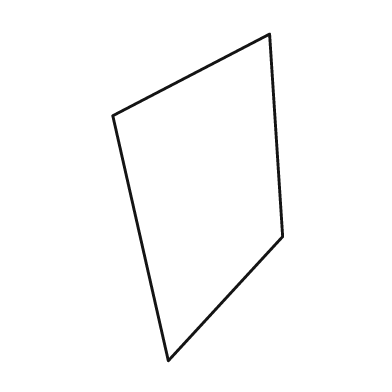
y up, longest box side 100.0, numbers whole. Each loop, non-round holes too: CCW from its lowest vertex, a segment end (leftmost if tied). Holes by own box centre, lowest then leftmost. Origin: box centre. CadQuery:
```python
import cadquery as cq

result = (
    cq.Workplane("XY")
    .moveTo(-9.0, -50.0)
    .lineTo(26.0, -12.0)
    .lineTo(22.0, 50.0)
    .lineTo(-26.0, 25.0)
    .close()
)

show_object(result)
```